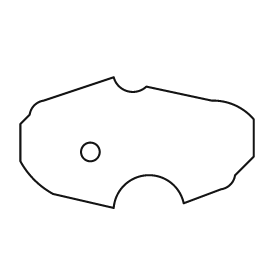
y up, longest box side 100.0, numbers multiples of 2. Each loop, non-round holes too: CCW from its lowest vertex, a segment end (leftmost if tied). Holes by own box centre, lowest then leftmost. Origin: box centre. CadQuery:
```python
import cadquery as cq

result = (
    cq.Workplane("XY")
    .moveTo(-10.0, -28.0)
    .threePointArc((4.0, -14.0), (20.0, -26.0))
    .lineTo(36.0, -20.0)
    .threePointArc((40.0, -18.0), (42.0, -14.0))
    .lineTo(50.0, -6.0)
    .lineTo(50.0, 10.0)
    .threePointArc((42.0, 16.0), (32.0, 18.0))
    .lineTo(4.0, 24.0)
    .threePointArc((-4.0, 22.0), (-10.0, 28.0))
    .lineTo(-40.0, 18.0)
    .threePointArc((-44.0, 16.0), (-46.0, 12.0))
    .lineTo(-50.0, 8.0)
    .lineTo(-50.0, -8.0)
    .threePointArc((-44.0, -16.0), (-36.0, -22.0))
    .close()
    .moveTo(-20.0, -4.0)
    .circle(4.0)
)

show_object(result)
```